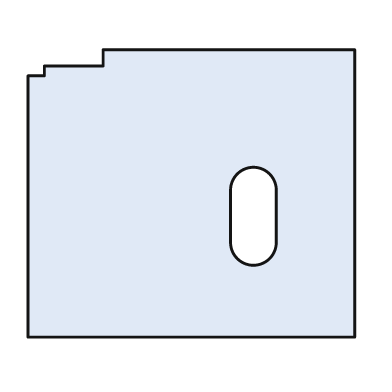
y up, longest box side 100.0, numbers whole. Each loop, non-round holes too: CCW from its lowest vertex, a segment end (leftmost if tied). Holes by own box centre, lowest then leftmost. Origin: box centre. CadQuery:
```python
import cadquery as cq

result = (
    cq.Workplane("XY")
    .moveTo(-50.0, -44.0)
    .lineTo(50.0, -44.0)
    .lineTo(50.0, 44.0)
    .lineTo(-27.0, 44.0)
    .lineTo(-27.0, 39.0)
    .lineTo(-45.0, 39.0)
    .lineTo(-45.0, 36.0)
    .lineTo(-50.0, 36.0)
    .close()
    .moveTo(12.0, -15.0)
    .threePointArc((19.0, -22.0), (26.0, -15.0))
    .lineTo(26.0, 1.0)
    .threePointArc((19.0, 8.0), (12.0, 1.0))
    .close()
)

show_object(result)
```